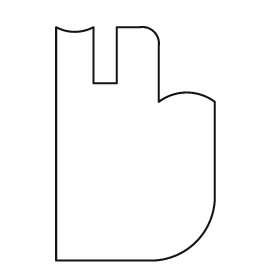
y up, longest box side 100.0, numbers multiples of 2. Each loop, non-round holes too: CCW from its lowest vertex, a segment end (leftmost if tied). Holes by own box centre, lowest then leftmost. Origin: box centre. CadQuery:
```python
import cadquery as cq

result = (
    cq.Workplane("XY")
    .moveTo(-34.0, -50.0)
    .lineTo(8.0, -50.0)
    .threePointArc((26.0, -42.0), (34.0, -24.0))
    .lineTo(34.0, 18.0)
    .threePointArc((22.0, 22.0), (10.0, 18.0))
    .lineTo(10.0, 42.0)
    .threePointArc((8.0, 48.0), (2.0, 50.0))
    .lineTo(-8.0, 50.0)
    .lineTo(-8.0, 26.0)
    .lineTo(-18.0, 26.0)
    .lineTo(-18.0, 50.0)
    .threePointArc((-26.0, 48.0), (-34.0, 50.0))
    .close()
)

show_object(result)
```